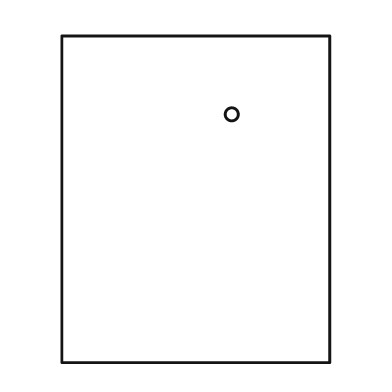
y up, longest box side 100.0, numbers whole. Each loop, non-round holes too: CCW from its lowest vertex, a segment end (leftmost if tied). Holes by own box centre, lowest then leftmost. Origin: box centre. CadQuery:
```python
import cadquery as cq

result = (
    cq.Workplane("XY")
    .moveTo(-41.0, -50.0)
    .lineTo(41.0, -50.0)
    .lineTo(41.0, 50.0)
    .lineTo(-41.0, 50.0)
    .close()
    .moveTo(11.0, 26.0)
    .circle(2.0)
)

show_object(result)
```